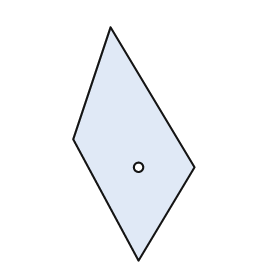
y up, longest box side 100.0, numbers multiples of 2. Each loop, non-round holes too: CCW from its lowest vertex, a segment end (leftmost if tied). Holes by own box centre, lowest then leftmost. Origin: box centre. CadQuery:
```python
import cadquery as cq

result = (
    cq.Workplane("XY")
    .moveTo(2.0, -50.0)
    .lineTo(26.0, -10.0)
    .lineTo(-10.0, 50.0)
    .lineTo(-26.0, 2.0)
    .close()
    .moveTo(2.0, -10.0)
    .circle(2.0)
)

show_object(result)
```